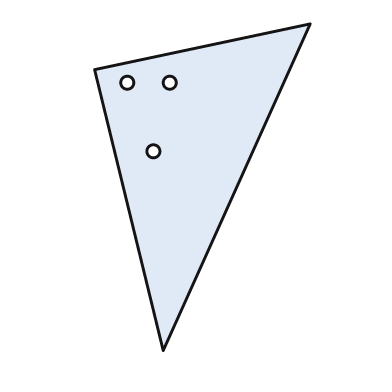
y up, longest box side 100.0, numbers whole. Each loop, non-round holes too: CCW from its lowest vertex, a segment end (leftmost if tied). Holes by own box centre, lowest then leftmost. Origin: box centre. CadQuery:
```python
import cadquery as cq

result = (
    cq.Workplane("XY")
    .moveTo(-12.0, -50.0)
    .lineTo(33.0, 50.0)
    .lineTo(-33.0, 36.0)
    .close()
    .moveTo(-15.0, 11.0)
    .circle(2.0)
    .moveTo(-23.0, 32.0)
    .circle(2.0)
    .moveTo(-10.0, 32.0)
    .circle(2.0)
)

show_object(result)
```